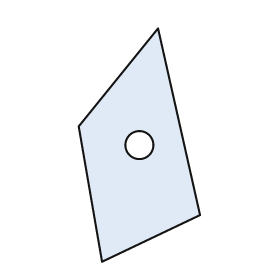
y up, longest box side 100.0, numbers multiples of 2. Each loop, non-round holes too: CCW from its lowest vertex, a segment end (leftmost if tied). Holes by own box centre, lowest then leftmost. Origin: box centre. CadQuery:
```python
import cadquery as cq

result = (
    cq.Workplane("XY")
    .moveTo(-16.0, -50.0)
    .lineTo(26.0, -30.0)
    .lineTo(8.0, 50.0)
    .lineTo(-26.0, 8.0)
    .close()
    .moveTo(0.0, 0.0)
    .circle(6.0)
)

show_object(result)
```